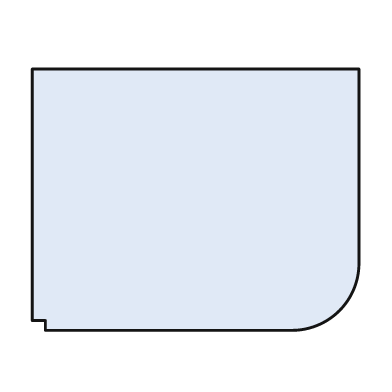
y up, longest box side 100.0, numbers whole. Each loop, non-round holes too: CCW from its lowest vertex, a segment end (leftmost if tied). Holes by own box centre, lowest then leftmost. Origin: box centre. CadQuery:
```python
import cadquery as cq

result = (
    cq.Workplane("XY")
    .moveTo(-46.0, -40.0)
    .lineTo(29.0, -40.0)
    .threePointArc((44.0, -34.0), (50.0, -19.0))
    .lineTo(50.0, 40.0)
    .lineTo(-50.0, 40.0)
    .lineTo(-50.0, -37.0)
    .lineTo(-46.0, -37.0)
    .close()
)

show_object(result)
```